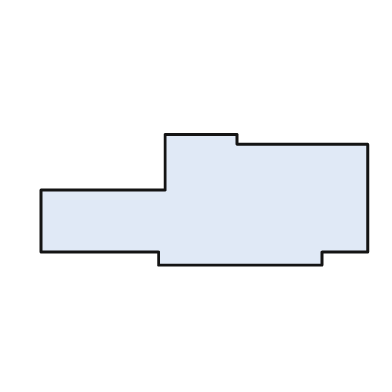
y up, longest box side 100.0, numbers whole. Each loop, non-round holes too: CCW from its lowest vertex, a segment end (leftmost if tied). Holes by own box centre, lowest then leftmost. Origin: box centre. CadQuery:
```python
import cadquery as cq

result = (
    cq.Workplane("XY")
    .moveTo(-14.0, -20.0)
    .lineTo(36.0, -20.0)
    .lineTo(36.0, -16.0)
    .lineTo(50.0, -16.0)
    .lineTo(50.0, 17.0)
    .lineTo(10.0, 17.0)
    .lineTo(10.0, 20.0)
    .lineTo(-12.0, 20.0)
    .lineTo(-12.0, 3.0)
    .lineTo(-50.0, 3.0)
    .lineTo(-50.0, -16.0)
    .lineTo(-14.0, -16.0)
    .close()
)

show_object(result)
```